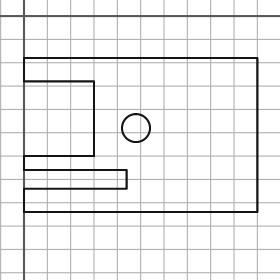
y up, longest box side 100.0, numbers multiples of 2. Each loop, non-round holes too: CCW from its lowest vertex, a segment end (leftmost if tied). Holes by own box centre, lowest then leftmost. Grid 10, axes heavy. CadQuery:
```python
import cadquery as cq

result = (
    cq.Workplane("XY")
    .moveTo(0.0, -84.0)
    .lineTo(100.0, -84.0)
    .lineTo(100.0, -18.0)
    .lineTo(0.0, -18.0)
    .lineTo(0.0, -28.0)
    .lineTo(30.0, -28.0)
    .lineTo(30.0, -60.0)
    .lineTo(0.0, -60.0)
    .lineTo(0.0, -66.0)
    .lineTo(44.0, -66.0)
    .lineTo(44.0, -74.0)
    .lineTo(0.0, -74.0)
    .close()
    .moveTo(48.0, -48.0)
    .circle(6.0)
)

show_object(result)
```